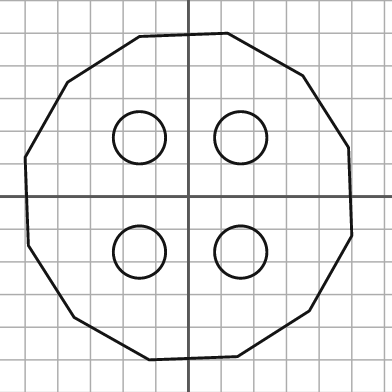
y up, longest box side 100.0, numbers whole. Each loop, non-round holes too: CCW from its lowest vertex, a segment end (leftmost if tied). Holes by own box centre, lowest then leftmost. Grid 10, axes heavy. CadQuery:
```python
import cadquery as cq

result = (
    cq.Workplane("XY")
    .moveTo(-12.0, -50.0)
    .lineTo(15.0, -49.0)
    .lineTo(37.0, -35.0)
    .lineTo(50.0, -12.0)
    .lineTo(49.0, 15.0)
    .lineTo(35.0, 37.0)
    .lineTo(12.0, 50.0)
    .lineTo(-15.0, 49.0)
    .lineTo(-37.0, 35.0)
    .lineTo(-50.0, 12.0)
    .lineTo(-49.0, -15.0)
    .lineTo(-35.0, -37.0)
    .close()
    .moveTo(-15.0, -17.0)
    .circle(8.0)
    .moveTo(16.0, -17.0)
    .circle(8.0)
    .moveTo(-15.0, 18.0)
    .circle(8.0)
    .moveTo(16.0, 18.0)
    .circle(8.0)
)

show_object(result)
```